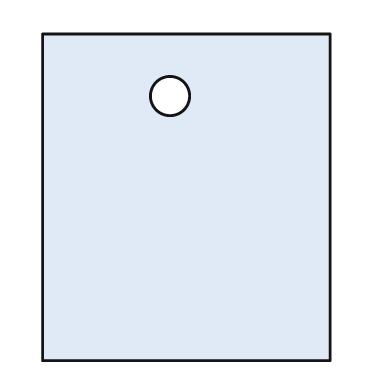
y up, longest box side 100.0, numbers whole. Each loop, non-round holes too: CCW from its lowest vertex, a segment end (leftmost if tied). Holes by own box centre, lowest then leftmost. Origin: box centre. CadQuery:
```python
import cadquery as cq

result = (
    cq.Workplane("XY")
    .moveTo(-44.0, -50.0)
    .lineTo(44.0, -50.0)
    .lineTo(44.0, 50.0)
    .lineTo(-44.0, 50.0)
    .close()
    .moveTo(-5.0, 31.0)
    .circle(6.0)
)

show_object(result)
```